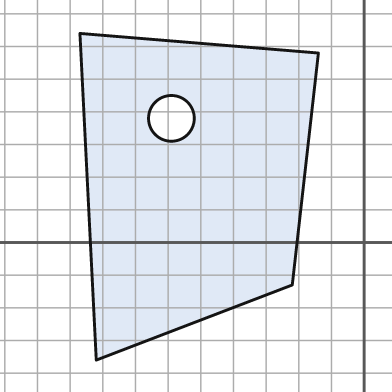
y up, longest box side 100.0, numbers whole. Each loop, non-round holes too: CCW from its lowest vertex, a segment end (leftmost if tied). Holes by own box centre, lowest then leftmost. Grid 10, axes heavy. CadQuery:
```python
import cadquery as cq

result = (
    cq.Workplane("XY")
    .moveTo(-82.0, -36.0)
    .lineTo(-22.0, -13.0)
    .lineTo(-14.0, 58.0)
    .lineTo(-87.0, 64.0)
    .close()
    .moveTo(-59.0, 38.0)
    .circle(7.0)
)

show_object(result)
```